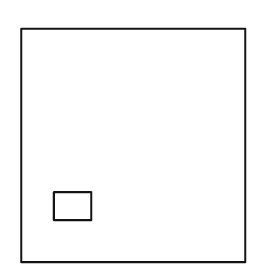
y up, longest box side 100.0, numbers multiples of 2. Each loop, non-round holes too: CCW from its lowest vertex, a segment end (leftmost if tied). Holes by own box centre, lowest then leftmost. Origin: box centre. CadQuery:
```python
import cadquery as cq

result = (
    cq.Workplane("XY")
    .moveTo(-48.0, -50.0)
    .lineTo(48.0, -50.0)
    .lineTo(48.0, 50.0)
    .lineTo(-48.0, 50.0)
    .close()
    .moveTo(-34.0, -32.0)
    .lineTo(-18.0, -32.0)
    .lineTo(-18.0, -20.0)
    .lineTo(-34.0, -20.0)
    .close()
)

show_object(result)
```